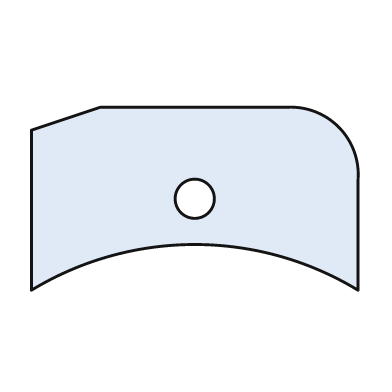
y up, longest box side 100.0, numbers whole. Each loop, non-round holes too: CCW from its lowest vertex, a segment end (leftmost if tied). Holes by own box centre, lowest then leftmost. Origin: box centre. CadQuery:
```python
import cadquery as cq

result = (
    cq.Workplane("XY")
    .moveTo(-50.0, -28.0)
    .threePointArc((0.0, -14.0), (50.0, -28.0))
    .lineTo(50.0, 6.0)
    .threePointArc((44.0, 22.0), (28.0, 28.0))
    .lineTo(-29.0, 28.0)
    .lineTo(-50.0, 21.0)
    .close()
    .moveTo(0.0, 0.0)
    .circle(6.0)
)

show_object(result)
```